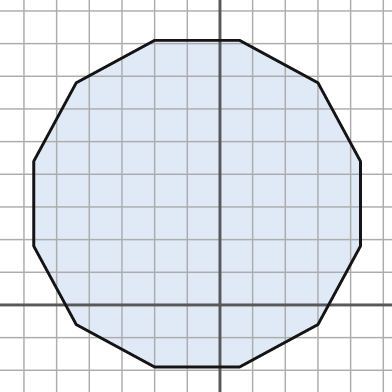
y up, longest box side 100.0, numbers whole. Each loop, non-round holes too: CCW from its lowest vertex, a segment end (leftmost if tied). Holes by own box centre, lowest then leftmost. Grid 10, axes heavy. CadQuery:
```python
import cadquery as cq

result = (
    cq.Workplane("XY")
    .moveTo(-20.0, -19.0)
    .lineTo(6.0, -19.0)
    .lineTo(30.0, -6.0)
    .lineTo(43.0, 18.0)
    .lineTo(43.0, 44.0)
    .lineTo(30.0, 68.0)
    .lineTo(6.0, 81.0)
    .lineTo(-20.0, 81.0)
    .lineTo(-44.0, 68.0)
    .lineTo(-57.0, 44.0)
    .lineTo(-57.0, 18.0)
    .lineTo(-44.0, -6.0)
    .close()
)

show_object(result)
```